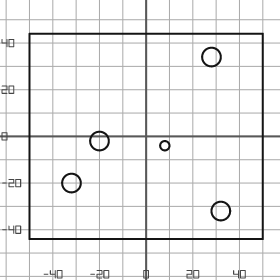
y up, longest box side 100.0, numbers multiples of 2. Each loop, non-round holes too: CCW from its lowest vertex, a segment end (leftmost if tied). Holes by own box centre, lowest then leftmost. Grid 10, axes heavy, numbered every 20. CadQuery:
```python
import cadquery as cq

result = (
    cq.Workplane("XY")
    .moveTo(-50.0, -44.0)
    .lineTo(50.0, -44.0)
    .lineTo(50.0, 44.0)
    .lineTo(-50.0, 44.0)
    .close()
    .moveTo(32.0, -32.0)
    .circle(4.0)
    .moveTo(-32.0, -20.0)
    .circle(4.0)
    .moveTo(8.0, -4.0)
    .circle(2.0)
    .moveTo(-20.0, -2.0)
    .circle(4.0)
    .moveTo(28.0, 34.0)
    .circle(4.0)
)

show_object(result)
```